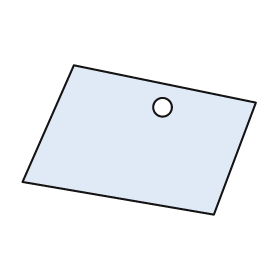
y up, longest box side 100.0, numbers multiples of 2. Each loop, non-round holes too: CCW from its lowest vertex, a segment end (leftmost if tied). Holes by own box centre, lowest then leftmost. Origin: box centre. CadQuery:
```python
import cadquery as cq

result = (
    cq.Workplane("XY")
    .moveTo(32.0, -32.0)
    .lineTo(50.0, 16.0)
    .lineTo(-28.0, 32.0)
    .lineTo(-50.0, -18.0)
    .close()
    .moveTo(10.0, 14.0)
    .circle(4.0)
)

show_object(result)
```